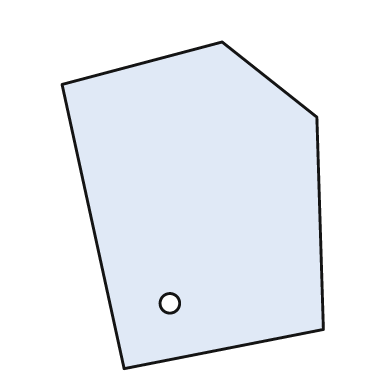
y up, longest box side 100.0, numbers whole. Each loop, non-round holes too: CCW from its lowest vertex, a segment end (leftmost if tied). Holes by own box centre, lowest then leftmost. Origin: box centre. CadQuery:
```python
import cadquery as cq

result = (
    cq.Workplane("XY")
    .moveTo(-21.0, -50.0)
    .lineTo(40.0, -38.0)
    .lineTo(38.0, 27.0)
    .lineTo(9.0, 50.0)
    .lineTo(-40.0, 37.0)
    .close()
    .moveTo(-7.0, -30.0)
    .circle(3.0)
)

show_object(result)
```